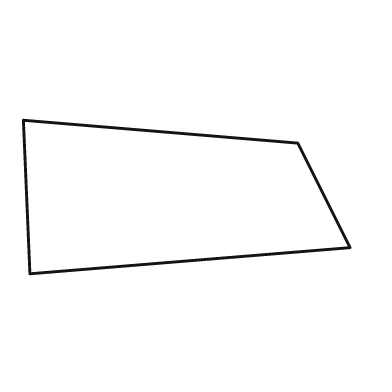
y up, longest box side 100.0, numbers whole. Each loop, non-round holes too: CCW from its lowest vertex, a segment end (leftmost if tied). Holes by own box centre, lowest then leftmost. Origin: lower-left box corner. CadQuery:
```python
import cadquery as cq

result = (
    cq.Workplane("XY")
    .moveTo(2.0, 0.0)
    .lineTo(100.0, 8.0)
    .lineTo(84.0, 40.0)
    .lineTo(0.0, 47.0)
    .close()
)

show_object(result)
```